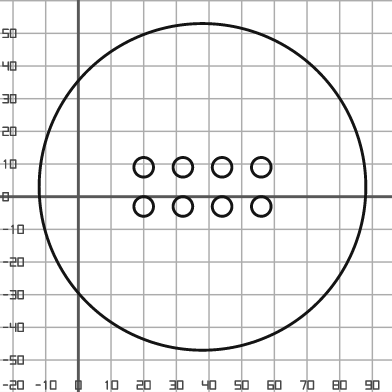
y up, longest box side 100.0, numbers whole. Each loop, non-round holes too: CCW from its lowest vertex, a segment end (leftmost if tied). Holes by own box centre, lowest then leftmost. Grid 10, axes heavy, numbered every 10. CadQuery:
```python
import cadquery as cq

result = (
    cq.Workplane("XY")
    .moveTo(38.0, 3.0)
    .circle(50.0)
    .moveTo(20.0, -3.0)
    .circle(3.0)
    .moveTo(32.0, -3.0)
    .circle(3.0)
    .moveTo(44.0, -3.0)
    .circle(3.0)
    .moveTo(56.0, -3.0)
    .circle(3.0)
    .moveTo(20.0, 9.0)
    .circle(3.0)
    .moveTo(32.0, 9.0)
    .circle(3.0)
    .moveTo(44.0, 9.0)
    .circle(3.0)
    .moveTo(56.0, 9.0)
    .circle(3.0)
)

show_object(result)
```